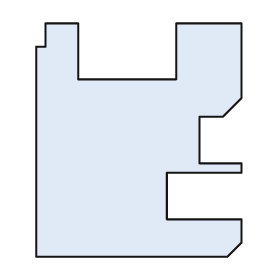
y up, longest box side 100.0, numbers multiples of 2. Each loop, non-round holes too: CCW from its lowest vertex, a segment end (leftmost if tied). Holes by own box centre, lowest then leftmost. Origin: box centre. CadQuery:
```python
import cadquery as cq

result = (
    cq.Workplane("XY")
    .moveTo(-44.0, -50.0)
    .lineTo(38.0, -50.0)
    .lineTo(44.0, -44.0)
    .lineTo(44.0, -34.0)
    .lineTo(12.0, -34.0)
    .lineTo(12.0, -14.0)
    .lineTo(44.0, -14.0)
    .lineTo(44.0, -10.0)
    .lineTo(26.0, -10.0)
    .lineTo(26.0, 10.0)
    .lineTo(36.0, 10.0)
    .lineTo(44.0, 18.0)
    .lineTo(44.0, 50.0)
    .lineTo(16.0, 50.0)
    .lineTo(16.0, 26.0)
    .lineTo(-26.0, 26.0)
    .lineTo(-26.0, 50.0)
    .lineTo(-40.0, 50.0)
    .lineTo(-40.0, 40.0)
    .lineTo(-44.0, 40.0)
    .close()
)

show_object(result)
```